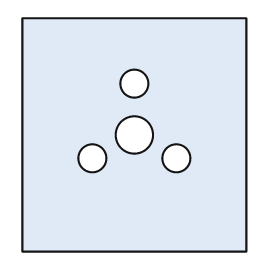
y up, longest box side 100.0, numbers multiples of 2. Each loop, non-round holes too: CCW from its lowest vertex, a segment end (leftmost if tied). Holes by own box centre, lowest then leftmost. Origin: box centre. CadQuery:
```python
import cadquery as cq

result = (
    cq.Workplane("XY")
    .moveTo(-48.0, -50.0)
    .lineTo(48.0, -50.0)
    .lineTo(48.0, 50.0)
    .lineTo(-48.0, 50.0)
    .close()
    .moveTo(-18.0, -10.0)
    .circle(6.0)
    .moveTo(18.0, -10.0)
    .circle(6.0)
    .moveTo(0.0, 0.0)
    .circle(8.0)
    .moveTo(0.0, 22.0)
    .circle(6.0)
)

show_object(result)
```